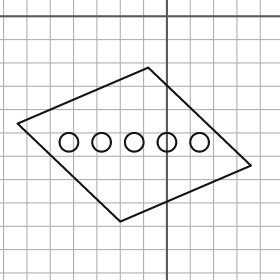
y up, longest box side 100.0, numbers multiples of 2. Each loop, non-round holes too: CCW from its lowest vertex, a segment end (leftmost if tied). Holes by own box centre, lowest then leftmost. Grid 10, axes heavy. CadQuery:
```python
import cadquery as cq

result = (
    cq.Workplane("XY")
    .moveTo(-20.0, -88.0)
    .lineTo(36.0, -64.0)
    .lineTo(-8.0, -22.0)
    .lineTo(-64.0, -46.0)
    .close()
    .moveTo(-42.0, -54.0)
    .circle(4.0)
    .moveTo(-28.0, -54.0)
    .circle(4.0)
    .moveTo(-14.0, -54.0)
    .circle(4.0)
    .moveTo(0.0, -54.0)
    .circle(4.0)
    .moveTo(14.0, -54.0)
    .circle(4.0)
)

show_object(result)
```